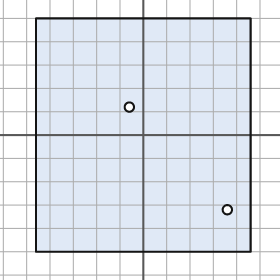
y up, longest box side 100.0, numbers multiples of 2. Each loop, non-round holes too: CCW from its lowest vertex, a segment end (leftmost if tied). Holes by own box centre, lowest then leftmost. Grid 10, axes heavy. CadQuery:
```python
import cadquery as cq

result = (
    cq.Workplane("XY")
    .moveTo(-46.0, -50.0)
    .lineTo(46.0, -50.0)
    .lineTo(46.0, 50.0)
    .lineTo(-46.0, 50.0)
    .close()
    .moveTo(36.0, -32.0)
    .circle(2.0)
    .moveTo(-6.0, 12.0)
    .circle(2.0)
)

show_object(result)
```